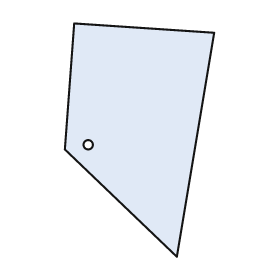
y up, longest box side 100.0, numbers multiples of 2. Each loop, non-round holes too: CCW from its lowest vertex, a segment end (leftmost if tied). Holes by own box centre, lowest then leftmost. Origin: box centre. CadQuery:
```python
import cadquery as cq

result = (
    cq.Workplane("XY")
    .moveTo(16.0, -50.0)
    .lineTo(32.0, 46.0)
    .lineTo(-28.0, 50.0)
    .lineTo(-32.0, -4.0)
    .close()
    .moveTo(-22.0, -2.0)
    .circle(2.0)
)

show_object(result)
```